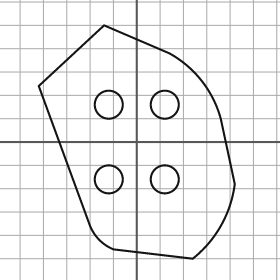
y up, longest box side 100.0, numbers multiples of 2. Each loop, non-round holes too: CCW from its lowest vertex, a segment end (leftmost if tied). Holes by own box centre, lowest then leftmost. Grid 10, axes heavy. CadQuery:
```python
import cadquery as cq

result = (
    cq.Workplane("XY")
    .moveTo(24.0, -50.0)
    .threePointArc((36.0, -36.0), (42.0, -18.0))
    .lineTo(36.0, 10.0)
    .threePointArc((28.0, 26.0), (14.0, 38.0))
    .lineTo(-14.0, 50.0)
    .lineTo(-42.0, 24.0)
    .lineTo(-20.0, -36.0)
    .threePointArc((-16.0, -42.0), (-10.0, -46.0))
    .close()
    .moveTo(-12.0, -16.0)
    .circle(6.0)
    .moveTo(12.0, -16.0)
    .circle(6.0)
    .moveTo(-12.0, 16.0)
    .circle(6.0)
    .moveTo(12.0, 16.0)
    .circle(6.0)
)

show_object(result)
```